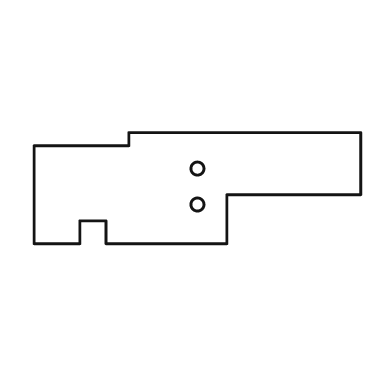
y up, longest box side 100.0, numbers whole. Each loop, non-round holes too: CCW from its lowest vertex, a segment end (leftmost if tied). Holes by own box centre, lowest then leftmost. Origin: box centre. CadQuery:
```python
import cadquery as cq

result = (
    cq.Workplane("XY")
    .moveTo(-50.0, -17.0)
    .lineTo(-36.0, -17.0)
    .lineTo(-36.0, -10.0)
    .lineTo(-28.0, -10.0)
    .lineTo(-28.0, -17.0)
    .lineTo(9.0, -17.0)
    .lineTo(9.0, -2.0)
    .lineTo(50.0, -2.0)
    .lineTo(50.0, 17.0)
    .lineTo(-21.0, 17.0)
    .lineTo(-21.0, 13.0)
    .lineTo(-50.0, 13.0)
    .close()
    .moveTo(0.0, -5.0)
    .circle(2.0)
    .moveTo(0.0, 6.0)
    .circle(2.0)
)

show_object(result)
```